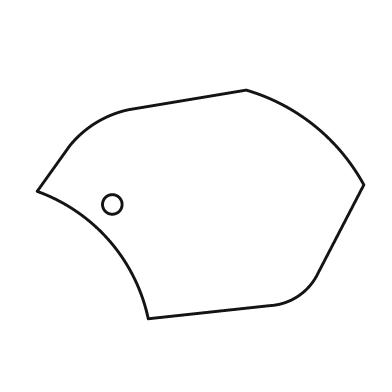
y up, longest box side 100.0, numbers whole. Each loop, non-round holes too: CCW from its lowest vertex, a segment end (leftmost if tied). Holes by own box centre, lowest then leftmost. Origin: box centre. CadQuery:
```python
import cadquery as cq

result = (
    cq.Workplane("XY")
    .moveTo(-16.0, -35.0)
    .lineTo(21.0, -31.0)
    .threePointArc((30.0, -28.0), (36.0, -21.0))
    .lineTo(50.0, 6.0)
    .threePointArc((35.0, 24.0), (14.0, 35.0))
    .lineTo(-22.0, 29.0)
    .threePointArc((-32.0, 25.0), (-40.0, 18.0))
    .lineTo(-50.0, 4.0)
    .threePointArc((-28.0, -11.0), (-16.0, -35.0))
    .close()
    .moveTo(-27.0, 0.0)
    .circle(3.0)
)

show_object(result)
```